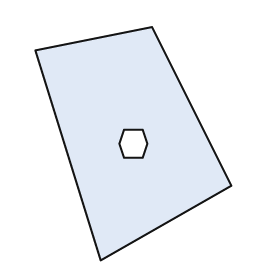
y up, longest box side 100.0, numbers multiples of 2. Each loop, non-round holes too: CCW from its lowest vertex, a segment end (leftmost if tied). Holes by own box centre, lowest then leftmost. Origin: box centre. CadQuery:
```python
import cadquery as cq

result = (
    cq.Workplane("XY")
    .moveTo(-14.0, -50.0)
    .lineTo(42.0, -18.0)
    .lineTo(8.0, 50.0)
    .lineTo(-42.0, 40.0)
    .close()
    .moveTo(-4.0, -6.0)
    .lineTo(4.0, -6.0)
    .lineTo(6.0, 0.0)
    .lineTo(4.0, 6.0)
    .lineTo(-4.0, 6.0)
    .lineTo(-6.0, 0.0)
    .close()
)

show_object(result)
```